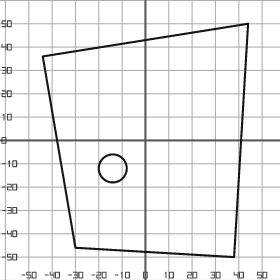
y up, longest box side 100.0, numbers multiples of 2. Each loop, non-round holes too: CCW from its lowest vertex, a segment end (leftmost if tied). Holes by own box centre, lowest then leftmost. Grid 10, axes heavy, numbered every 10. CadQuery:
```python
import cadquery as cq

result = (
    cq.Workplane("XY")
    .moveTo(38.0, -50.0)
    .lineTo(44.0, 50.0)
    .lineTo(-44.0, 36.0)
    .lineTo(-30.0, -46.0)
    .close()
    .moveTo(-14.0, -12.0)
    .circle(6.0)
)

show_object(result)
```